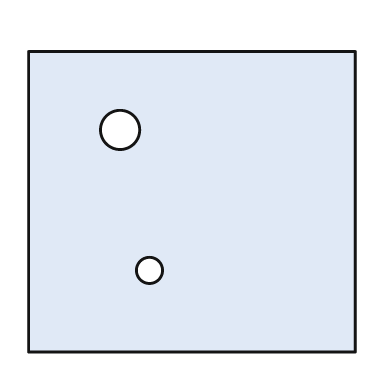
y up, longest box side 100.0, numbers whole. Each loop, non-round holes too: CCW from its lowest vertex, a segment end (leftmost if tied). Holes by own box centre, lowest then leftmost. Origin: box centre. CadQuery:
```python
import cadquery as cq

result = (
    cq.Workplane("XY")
    .moveTo(-50.0, -46.0)
    .lineTo(50.0, -46.0)
    .lineTo(50.0, 46.0)
    .lineTo(-50.0, 46.0)
    .close()
    .moveTo(-13.0, -21.0)
    .circle(4.0)
    .moveTo(-22.0, 22.0)
    .circle(6.0)
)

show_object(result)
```